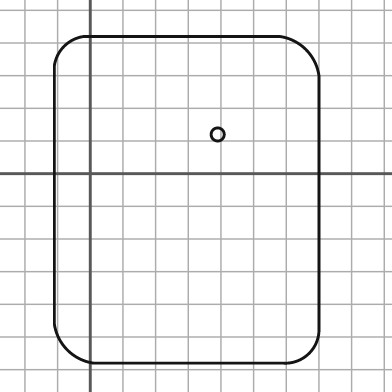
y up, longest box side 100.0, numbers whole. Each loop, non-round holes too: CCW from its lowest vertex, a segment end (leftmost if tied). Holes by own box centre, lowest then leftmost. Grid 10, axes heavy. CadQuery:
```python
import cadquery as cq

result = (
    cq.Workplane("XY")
    .moveTo(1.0, -58.0)
    .lineTo(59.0, -58.0)
    .threePointArc((67.0, -55.0), (70.0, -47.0))
    .lineTo(70.0, 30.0)
    .threePointArc((66.0, 38.0), (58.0, 42.0))
    .lineTo(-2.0, 42.0)
    .threePointArc((-8.0, 39.0), (-11.0, 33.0))
    .lineTo(-11.0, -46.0)
    .threePointArc((-7.0, -54.0), (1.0, -58.0))
    .close()
    .moveTo(39.0, 12.0)
    .circle(2.0)
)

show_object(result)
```